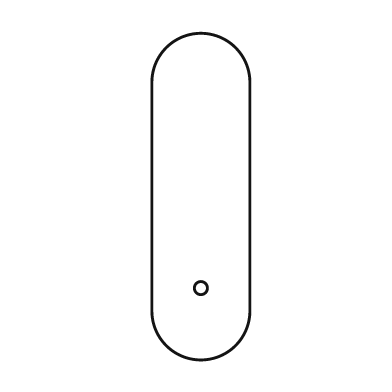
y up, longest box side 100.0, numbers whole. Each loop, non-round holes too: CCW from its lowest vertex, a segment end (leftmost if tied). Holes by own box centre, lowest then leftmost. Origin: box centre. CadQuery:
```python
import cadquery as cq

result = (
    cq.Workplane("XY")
    .moveTo(-15.0, -35.0)
    .threePointArc((0.0, -50.0), (15.0, -35.0))
    .lineTo(15.0, 35.0)
    .threePointArc((0.0, 50.0), (-15.0, 35.0))
    .close()
    .moveTo(0.0, -28.0)
    .circle(2.0)
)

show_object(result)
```